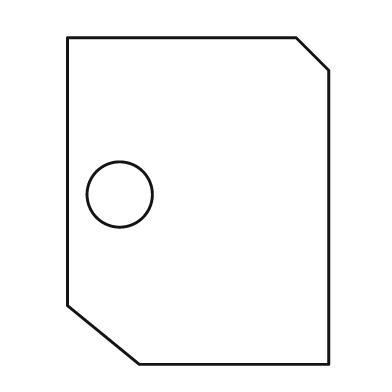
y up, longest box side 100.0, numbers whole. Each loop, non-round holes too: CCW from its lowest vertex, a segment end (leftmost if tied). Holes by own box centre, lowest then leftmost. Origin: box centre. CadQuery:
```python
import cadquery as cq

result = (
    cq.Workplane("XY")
    .moveTo(-18.0, -50.0)
    .lineTo(40.0, -50.0)
    .lineTo(40.0, 40.0)
    .lineTo(30.0, 50.0)
    .lineTo(-40.0, 50.0)
    .lineTo(-40.0, -32.0)
    .close()
    .moveTo(-24.0, 2.0)
    .circle(10.0)
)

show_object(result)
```